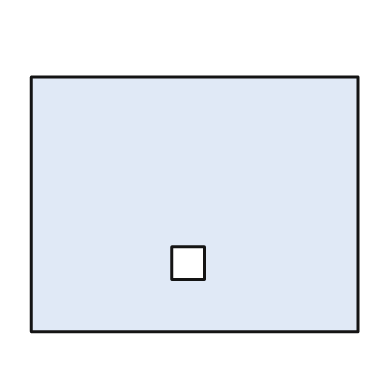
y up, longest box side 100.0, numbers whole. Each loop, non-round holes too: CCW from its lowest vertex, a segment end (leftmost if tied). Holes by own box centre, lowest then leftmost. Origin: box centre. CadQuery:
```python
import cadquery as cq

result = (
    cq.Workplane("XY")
    .moveTo(-50.0, -39.0)
    .lineTo(50.0, -39.0)
    .lineTo(50.0, 39.0)
    .lineTo(-50.0, 39.0)
    .close()
    .moveTo(-7.0, -23.0)
    .lineTo(3.0, -23.0)
    .lineTo(3.0, -13.0)
    .lineTo(-7.0, -13.0)
    .close()
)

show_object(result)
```